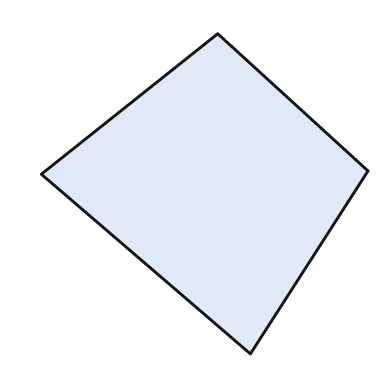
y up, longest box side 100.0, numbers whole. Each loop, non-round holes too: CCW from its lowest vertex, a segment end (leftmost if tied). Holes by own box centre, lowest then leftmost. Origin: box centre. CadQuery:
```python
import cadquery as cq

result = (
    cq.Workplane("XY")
    .moveTo(14.0, -49.0)
    .lineTo(50.0, 7.0)
    .lineTo(4.0, 49.0)
    .lineTo(-50.0, 6.0)
    .close()
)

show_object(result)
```